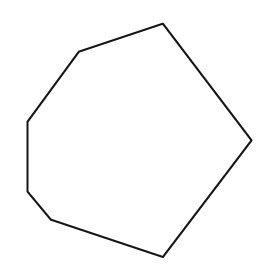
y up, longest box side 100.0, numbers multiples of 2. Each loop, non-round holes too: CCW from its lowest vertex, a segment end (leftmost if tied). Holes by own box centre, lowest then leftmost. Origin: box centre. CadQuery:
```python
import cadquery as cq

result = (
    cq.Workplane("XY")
    .moveTo(10.0, -50.0)
    .lineTo(48.0, 0.0)
    .lineTo(10.0, 50.0)
    .lineTo(-26.0, 38.0)
    .lineTo(-48.0, 8.0)
    .lineTo(-48.0, -22.0)
    .lineTo(-38.0, -34.0)
    .close()
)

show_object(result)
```